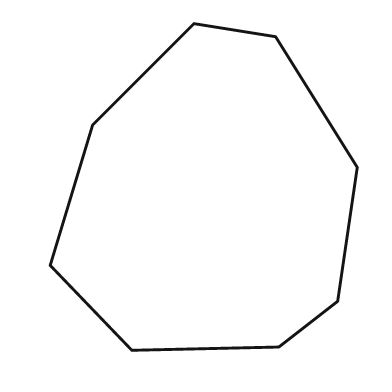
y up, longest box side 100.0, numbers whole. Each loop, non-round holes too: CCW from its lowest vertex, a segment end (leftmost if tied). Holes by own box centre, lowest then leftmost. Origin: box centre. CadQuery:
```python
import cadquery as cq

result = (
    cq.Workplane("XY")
    .moveTo(-22.0, -50.0)
    .lineTo(23.0, -49.0)
    .lineTo(41.0, -35.0)
    .lineTo(47.0, 6.0)
    .lineTo(22.0, 46.0)
    .lineTo(-3.0, 50.0)
    .lineTo(-34.0, 19.0)
    .lineTo(-47.0, -24.0)
    .close()
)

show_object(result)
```